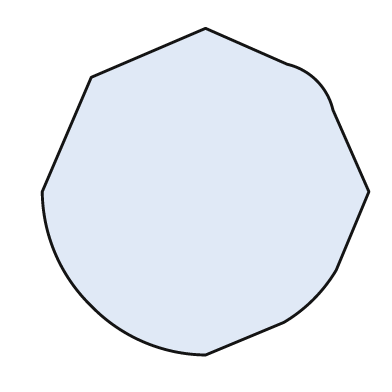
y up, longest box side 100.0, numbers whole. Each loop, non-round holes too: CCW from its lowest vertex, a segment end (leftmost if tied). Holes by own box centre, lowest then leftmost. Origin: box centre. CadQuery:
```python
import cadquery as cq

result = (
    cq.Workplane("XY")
    .moveTo(0.0, -50.0)
    .lineTo(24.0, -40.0)
    .threePointArc((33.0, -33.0), (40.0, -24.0))
    .lineTo(50.0, 0.0)
    .lineTo(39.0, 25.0)
    .threePointArc((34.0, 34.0), (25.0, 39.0))
    .lineTo(0.0, 50.0)
    .lineTo(-35.0, 35.0)
    .lineTo(-50.0, 0.0)
    .threePointArc((-46.0, -19.0), (-35.0, -35.0))
    .threePointArc((-19.0, -46.0), (0.0, -50.0))
    .close()
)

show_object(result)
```